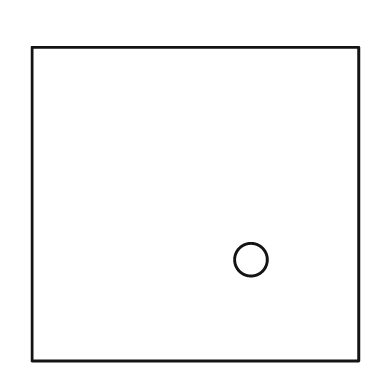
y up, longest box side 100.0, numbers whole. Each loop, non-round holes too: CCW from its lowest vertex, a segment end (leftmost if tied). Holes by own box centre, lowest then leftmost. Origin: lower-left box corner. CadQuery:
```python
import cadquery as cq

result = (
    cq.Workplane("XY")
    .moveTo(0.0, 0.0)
    .lineTo(100.0, 0.0)
    .lineTo(100.0, 96.0)
    .lineTo(0.0, 96.0)
    .close()
    .moveTo(67.0, 31.0)
    .circle(5.0)
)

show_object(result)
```